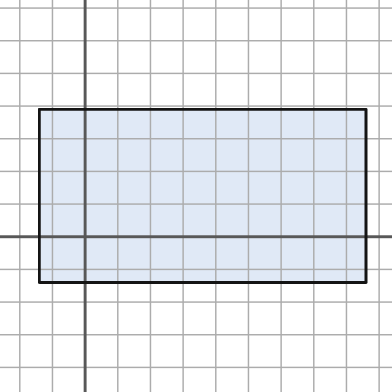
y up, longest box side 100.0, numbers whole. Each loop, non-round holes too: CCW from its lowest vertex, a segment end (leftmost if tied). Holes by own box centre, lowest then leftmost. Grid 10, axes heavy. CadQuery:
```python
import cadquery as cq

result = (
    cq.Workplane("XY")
    .moveTo(-14.0, -14.0)
    .lineTo(86.0, -14.0)
    .lineTo(86.0, 39.0)
    .lineTo(-14.0, 39.0)
    .close()
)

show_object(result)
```